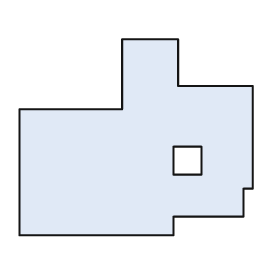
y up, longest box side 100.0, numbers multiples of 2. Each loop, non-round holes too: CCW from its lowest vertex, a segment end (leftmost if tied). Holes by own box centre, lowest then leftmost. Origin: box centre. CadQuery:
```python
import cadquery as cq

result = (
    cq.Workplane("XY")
    .moveTo(-50.0, -42.0)
    .lineTo(16.0, -42.0)
    .lineTo(16.0, -34.0)
    .lineTo(46.0, -34.0)
    .lineTo(46.0, -22.0)
    .lineTo(50.0, -22.0)
    .lineTo(50.0, 22.0)
    .lineTo(18.0, 22.0)
    .lineTo(18.0, 42.0)
    .lineTo(-6.0, 42.0)
    .lineTo(-6.0, 12.0)
    .lineTo(-50.0, 12.0)
    .close()
    .moveTo(16.0, -16.0)
    .lineTo(28.0, -16.0)
    .lineTo(28.0, -4.0)
    .lineTo(16.0, -4.0)
    .close()
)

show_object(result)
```